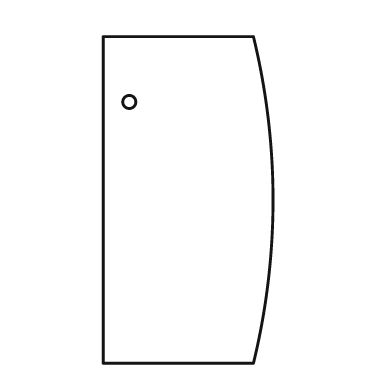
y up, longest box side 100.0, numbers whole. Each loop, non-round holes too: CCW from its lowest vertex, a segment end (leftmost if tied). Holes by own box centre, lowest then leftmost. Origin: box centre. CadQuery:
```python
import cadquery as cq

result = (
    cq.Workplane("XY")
    .moveTo(-26.0, -50.0)
    .lineTo(20.0, -50.0)
    .threePointArc((26.0, 0.0), (20.0, 50.0))
    .lineTo(-26.0, 50.0)
    .close()
    .moveTo(-18.0, 30.0)
    .circle(2.0)
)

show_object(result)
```